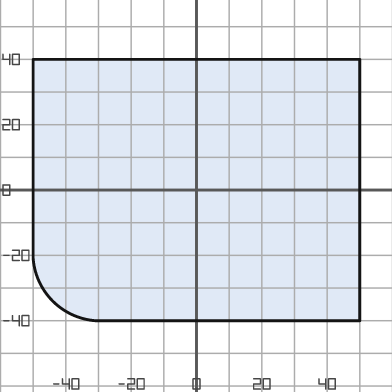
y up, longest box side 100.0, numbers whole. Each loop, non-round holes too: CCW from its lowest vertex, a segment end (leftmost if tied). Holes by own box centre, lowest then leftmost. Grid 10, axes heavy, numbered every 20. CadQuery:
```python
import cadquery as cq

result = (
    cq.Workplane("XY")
    .moveTo(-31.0, -40.0)
    .lineTo(50.0, -40.0)
    .lineTo(50.0, 40.0)
    .lineTo(-50.0, 40.0)
    .lineTo(-50.0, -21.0)
    .threePointArc((-44.0, -34.0), (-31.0, -40.0))
    .close()
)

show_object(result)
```